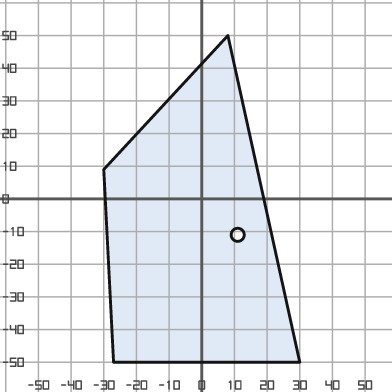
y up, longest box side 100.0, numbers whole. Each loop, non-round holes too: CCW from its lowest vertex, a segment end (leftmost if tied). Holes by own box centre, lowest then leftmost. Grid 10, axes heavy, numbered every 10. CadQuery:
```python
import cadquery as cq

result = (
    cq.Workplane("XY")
    .moveTo(-27.0, -50.0)
    .lineTo(30.0, -50.0)
    .lineTo(8.0, 50.0)
    .lineTo(-30.0, 9.0)
    .close()
    .moveTo(11.0, -11.0)
    .circle(2.0)
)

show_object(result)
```